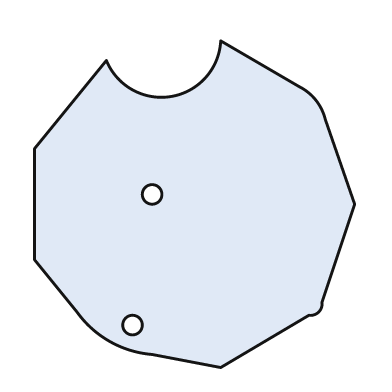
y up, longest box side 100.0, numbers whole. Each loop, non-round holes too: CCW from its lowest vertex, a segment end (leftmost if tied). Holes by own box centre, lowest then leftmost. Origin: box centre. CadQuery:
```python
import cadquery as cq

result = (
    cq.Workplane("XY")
    .moveTo(8.0, -50.0)
    .lineTo(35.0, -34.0)
    .threePointArc((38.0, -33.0), (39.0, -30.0))
    .lineTo(49.0, 0.0)
    .lineTo(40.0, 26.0)
    .threePointArc((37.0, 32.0), (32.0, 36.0))
    .lineTo(8.0, 50.0)
    .threePointArc((-7.0, 33.0), (-27.0, 44.0))
    .lineTo(-49.0, 17.0)
    .lineTo(-49.0, -17.0)
    .lineTo(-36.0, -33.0)
    .threePointArc((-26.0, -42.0), (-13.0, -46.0))
    .close()
    .moveTo(-19.0, -37.0)
    .circle(3.0)
    .moveTo(-13.0, 3.0)
    .circle(3.0)
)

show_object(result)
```